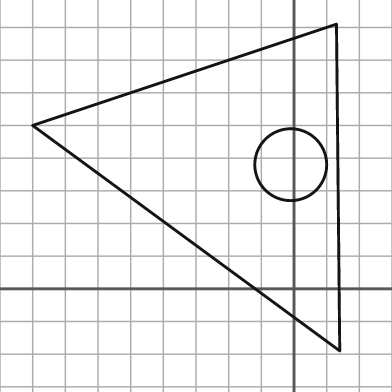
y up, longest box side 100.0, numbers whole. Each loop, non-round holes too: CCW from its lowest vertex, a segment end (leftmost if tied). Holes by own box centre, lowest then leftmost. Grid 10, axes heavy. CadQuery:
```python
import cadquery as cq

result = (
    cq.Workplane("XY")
    .moveTo(14.0, -19.0)
    .lineTo(13.0, 81.0)
    .lineTo(-80.0, 50.0)
    .close()
    .moveTo(-1.0, 38.0)
    .circle(11.0)
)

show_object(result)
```